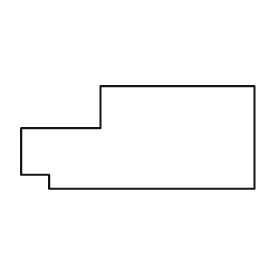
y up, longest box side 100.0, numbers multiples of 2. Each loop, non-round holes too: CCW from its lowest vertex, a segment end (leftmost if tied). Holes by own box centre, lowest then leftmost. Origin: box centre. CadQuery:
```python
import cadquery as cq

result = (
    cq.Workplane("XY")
    .moveTo(-38.0, -22.0)
    .lineTo(50.0, -22.0)
    .lineTo(50.0, 22.0)
    .lineTo(-16.0, 22.0)
    .lineTo(-16.0, 4.0)
    .lineTo(-50.0, 4.0)
    .lineTo(-50.0, -16.0)
    .lineTo(-38.0, -16.0)
    .close()
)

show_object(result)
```